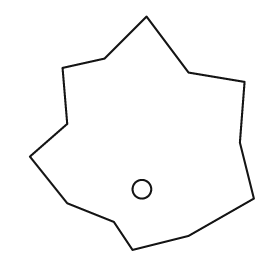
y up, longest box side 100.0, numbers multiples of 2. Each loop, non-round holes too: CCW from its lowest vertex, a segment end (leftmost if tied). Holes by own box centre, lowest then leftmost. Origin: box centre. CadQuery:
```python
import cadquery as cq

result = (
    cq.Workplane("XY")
    .moveTo(-4.0, -50.0)
    .lineTo(20.0, -44.0)
    .lineTo(48.0, -28.0)
    .lineTo(42.0, -4.0)
    .lineTo(44.0, 22.0)
    .lineTo(20.0, 26.0)
    .lineTo(2.0, 50.0)
    .lineTo(-16.0, 32.0)
    .lineTo(-34.0, 28.0)
    .lineTo(-32.0, 4.0)
    .lineTo(-48.0, -10.0)
    .lineTo(-32.0, -30.0)
    .lineTo(-12.0, -38.0)
    .close()
    .moveTo(0.0, -24.0)
    .circle(4.0)
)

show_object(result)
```